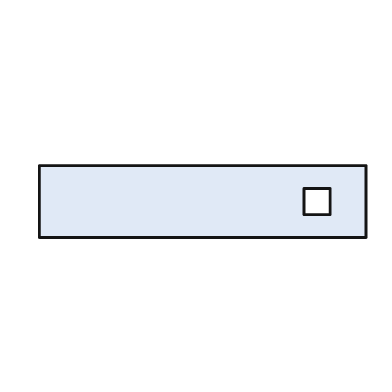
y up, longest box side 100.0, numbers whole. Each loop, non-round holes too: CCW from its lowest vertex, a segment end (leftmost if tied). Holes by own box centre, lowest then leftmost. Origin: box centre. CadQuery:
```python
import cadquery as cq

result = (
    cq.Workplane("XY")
    .moveTo(-50.0, -11.0)
    .lineTo(50.0, -11.0)
    .lineTo(50.0, 11.0)
    .lineTo(-50.0, 11.0)
    .close()
    .moveTo(31.0, -4.0)
    .lineTo(39.0, -4.0)
    .lineTo(39.0, 4.0)
    .lineTo(31.0, 4.0)
    .close()
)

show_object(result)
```